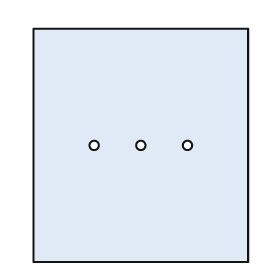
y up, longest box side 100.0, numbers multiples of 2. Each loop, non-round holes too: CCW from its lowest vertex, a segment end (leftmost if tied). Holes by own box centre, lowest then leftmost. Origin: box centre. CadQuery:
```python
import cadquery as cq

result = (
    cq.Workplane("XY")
    .moveTo(-46.0, -50.0)
    .lineTo(46.0, -50.0)
    .lineTo(46.0, 50.0)
    .lineTo(-46.0, 50.0)
    .close()
    .moveTo(-20.0, 0.0)
    .circle(2.0)
    .moveTo(0.0, 0.0)
    .circle(2.0)
    .moveTo(20.0, 0.0)
    .circle(2.0)
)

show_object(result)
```